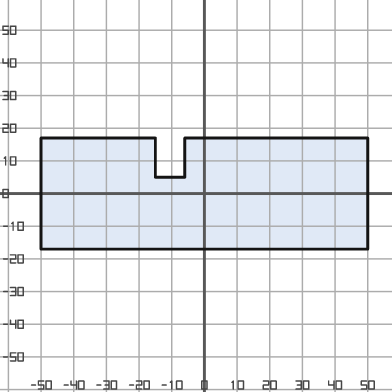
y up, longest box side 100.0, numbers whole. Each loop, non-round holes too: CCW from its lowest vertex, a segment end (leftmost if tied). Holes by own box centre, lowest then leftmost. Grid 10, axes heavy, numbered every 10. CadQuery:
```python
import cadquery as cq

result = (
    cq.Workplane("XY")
    .moveTo(-50.0, -17.0)
    .lineTo(50.0, -17.0)
    .lineTo(50.0, 17.0)
    .lineTo(-6.0, 17.0)
    .lineTo(-6.0, 5.0)
    .lineTo(-15.0, 5.0)
    .lineTo(-15.0, 17.0)
    .lineTo(-50.0, 17.0)
    .close()
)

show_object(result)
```